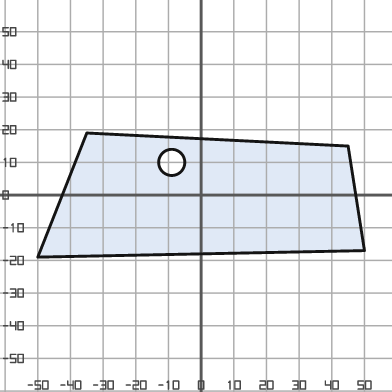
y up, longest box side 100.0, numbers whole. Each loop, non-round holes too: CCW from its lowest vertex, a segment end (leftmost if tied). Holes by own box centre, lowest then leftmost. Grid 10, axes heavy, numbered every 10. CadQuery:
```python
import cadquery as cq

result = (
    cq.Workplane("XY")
    .moveTo(-50.0, -19.0)
    .lineTo(50.0, -17.0)
    .lineTo(45.0, 15.0)
    .lineTo(-35.0, 19.0)
    .close()
    .moveTo(-9.0, 10.0)
    .circle(4.0)
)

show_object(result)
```